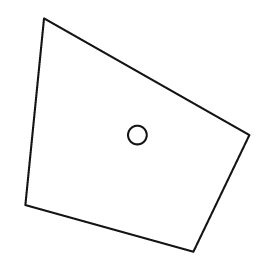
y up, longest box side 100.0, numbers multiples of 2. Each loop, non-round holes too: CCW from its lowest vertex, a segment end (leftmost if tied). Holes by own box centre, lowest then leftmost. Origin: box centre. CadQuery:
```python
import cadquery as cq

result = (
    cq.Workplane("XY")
    .moveTo(24.0, -50.0)
    .lineTo(48.0, 0.0)
    .lineTo(-40.0, 50.0)
    .lineTo(-48.0, -30.0)
    .close()
    .moveTo(0.0, 0.0)
    .circle(4.0)
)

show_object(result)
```